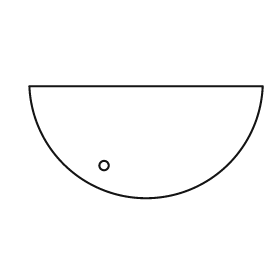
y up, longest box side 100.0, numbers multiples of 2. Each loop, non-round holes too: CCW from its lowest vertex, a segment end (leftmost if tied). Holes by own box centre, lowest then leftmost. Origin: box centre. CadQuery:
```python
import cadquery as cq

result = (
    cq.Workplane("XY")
    .moveTo(-50.0, 24.0)
    .threePointArc((0.0, -24.0), (50.0, 24.0))
    .close()
    .moveTo(-18.0, -10.0)
    .circle(2.0)
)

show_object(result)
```